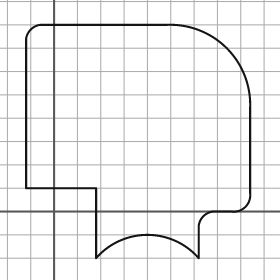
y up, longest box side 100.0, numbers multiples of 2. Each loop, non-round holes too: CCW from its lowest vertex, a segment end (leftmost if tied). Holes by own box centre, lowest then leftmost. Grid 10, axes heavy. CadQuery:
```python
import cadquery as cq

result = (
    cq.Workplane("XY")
    .moveTo(18.0, -20.0)
    .threePointArc((40.0, -10.0), (62.0, -20.0))
    .lineTo(62.0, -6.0)
    .threePointArc((64.0, -2.0), (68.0, 0.0))
    .lineTo(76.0, 0.0)
    .threePointArc((82.0, 2.0), (84.0, 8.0))
    .lineTo(84.0, 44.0)
    .threePointArc((74.0, 70.0), (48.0, 80.0))
    .lineTo(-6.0, 80.0)
    .threePointArc((-10.0, 78.0), (-12.0, 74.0))
    .lineTo(-12.0, 10.0)
    .lineTo(18.0, 10.0)
    .close()
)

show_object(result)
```